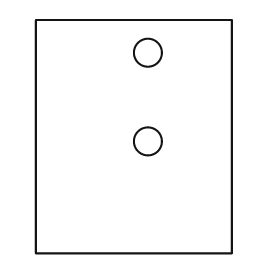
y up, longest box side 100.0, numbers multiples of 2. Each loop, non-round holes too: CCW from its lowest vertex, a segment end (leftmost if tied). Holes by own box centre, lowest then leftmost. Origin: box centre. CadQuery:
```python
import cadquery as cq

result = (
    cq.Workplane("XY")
    .moveTo(-42.0, -50.0)
    .lineTo(42.0, -50.0)
    .lineTo(42.0, 50.0)
    .lineTo(-42.0, 50.0)
    .close()
    .moveTo(6.0, -2.0)
    .circle(6.0)
    .moveTo(6.0, 36.0)
    .circle(6.0)
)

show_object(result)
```